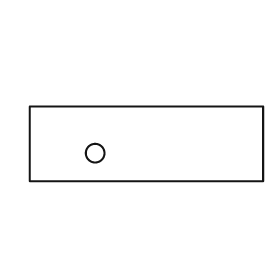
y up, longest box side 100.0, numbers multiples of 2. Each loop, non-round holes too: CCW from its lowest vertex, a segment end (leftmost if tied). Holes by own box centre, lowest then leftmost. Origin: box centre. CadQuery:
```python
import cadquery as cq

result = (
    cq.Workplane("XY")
    .moveTo(-50.0, -16.0)
    .lineTo(50.0, -16.0)
    .lineTo(50.0, 16.0)
    .lineTo(-50.0, 16.0)
    .close()
    .moveTo(-22.0, -4.0)
    .circle(4.0)
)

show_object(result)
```